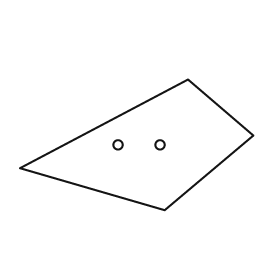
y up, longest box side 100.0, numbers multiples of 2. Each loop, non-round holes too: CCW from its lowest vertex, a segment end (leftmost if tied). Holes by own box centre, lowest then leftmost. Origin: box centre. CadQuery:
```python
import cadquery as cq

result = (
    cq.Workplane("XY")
    .moveTo(12.0, -28.0)
    .lineTo(50.0, 4.0)
    .lineTo(22.0, 28.0)
    .lineTo(-50.0, -10.0)
    .close()
    .moveTo(-8.0, 0.0)
    .circle(2.0)
    .moveTo(10.0, 0.0)
    .circle(2.0)
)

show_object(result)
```